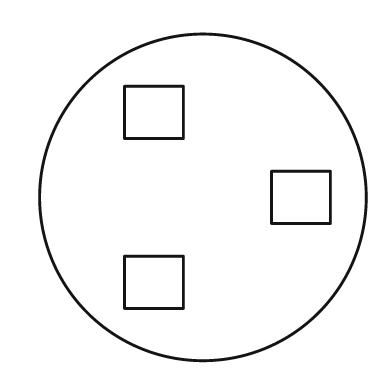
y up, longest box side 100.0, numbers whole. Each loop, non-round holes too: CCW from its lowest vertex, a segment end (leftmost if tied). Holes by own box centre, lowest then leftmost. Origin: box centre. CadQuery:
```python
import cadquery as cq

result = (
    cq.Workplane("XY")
    .moveTo(0.0, 0.0)
    .circle(50.0)
    .moveTo(-24.0, -34.0)
    .lineTo(-6.0, -34.0)
    .lineTo(-6.0, -18.0)
    .lineTo(-24.0, -18.0)
    .close()
    .moveTo(21.0, -8.0)
    .lineTo(39.0, -8.0)
    .lineTo(39.0, 8.0)
    .lineTo(21.0, 8.0)
    .close()
    .moveTo(-24.0, 18.0)
    .lineTo(-6.0, 18.0)
    .lineTo(-6.0, 34.0)
    .lineTo(-24.0, 34.0)
    .close()
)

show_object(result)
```